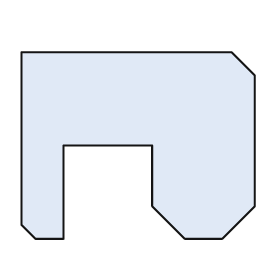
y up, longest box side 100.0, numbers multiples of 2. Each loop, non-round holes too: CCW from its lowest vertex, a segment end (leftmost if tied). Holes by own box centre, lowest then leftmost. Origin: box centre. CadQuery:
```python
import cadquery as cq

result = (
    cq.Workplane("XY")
    .moveTo(-44.0, -40.0)
    .lineTo(-32.0, -40.0)
    .lineTo(-32.0, 0.0)
    .lineTo(6.0, 0.0)
    .lineTo(6.0, -26.0)
    .lineTo(20.0, -40.0)
    .lineTo(36.0, -40.0)
    .lineTo(50.0, -26.0)
    .lineTo(50.0, 30.0)
    .lineTo(40.0, 40.0)
    .lineTo(-50.0, 40.0)
    .lineTo(-50.0, -34.0)
    .close()
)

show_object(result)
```